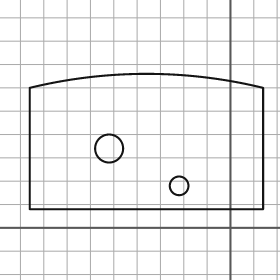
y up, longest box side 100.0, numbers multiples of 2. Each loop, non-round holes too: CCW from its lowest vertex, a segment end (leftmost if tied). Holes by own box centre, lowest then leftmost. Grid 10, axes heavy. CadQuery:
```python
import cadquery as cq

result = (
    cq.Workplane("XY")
    .moveTo(-86.0, 8.0)
    .lineTo(14.0, 8.0)
    .lineTo(14.0, 60.0)
    .threePointArc((-36.0, 66.0), (-86.0, 60.0))
    .close()
    .moveTo(-22.0, 18.0)
    .circle(4.0)
    .moveTo(-52.0, 34.0)
    .circle(6.0)
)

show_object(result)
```